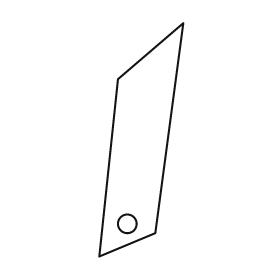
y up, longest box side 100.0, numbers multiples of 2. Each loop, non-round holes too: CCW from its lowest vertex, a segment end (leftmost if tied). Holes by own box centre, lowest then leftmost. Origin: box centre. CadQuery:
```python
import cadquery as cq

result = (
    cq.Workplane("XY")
    .moveTo(-18.0, -50.0)
    .lineTo(6.0, -40.0)
    .lineTo(18.0, 50.0)
    .lineTo(-10.0, 26.0)
    .close()
    .moveTo(-6.0, -36.0)
    .circle(4.0)
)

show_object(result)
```